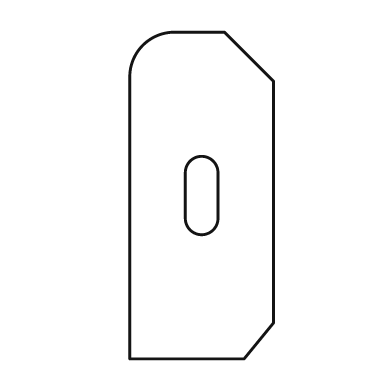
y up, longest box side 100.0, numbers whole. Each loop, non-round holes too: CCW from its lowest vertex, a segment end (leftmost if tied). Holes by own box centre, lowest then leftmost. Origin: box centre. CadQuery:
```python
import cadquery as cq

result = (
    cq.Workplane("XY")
    .moveTo(-22.0, -50.0)
    .lineTo(13.0, -50.0)
    .lineTo(22.0, -39.0)
    .lineTo(22.0, 35.0)
    .lineTo(7.0, 50.0)
    .lineTo(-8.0, 50.0)
    .threePointArc((-18.0, 46.0), (-22.0, 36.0))
    .close()
    .moveTo(-5.0, -7.0)
    .threePointArc((0.0, -12.0), (5.0, -7.0))
    .lineTo(5.0, 7.0)
    .threePointArc((0.0, 12.0), (-5.0, 7.0))
    .close()
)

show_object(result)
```